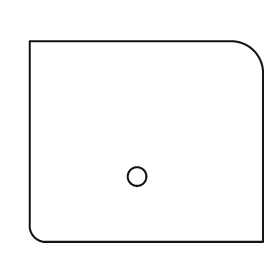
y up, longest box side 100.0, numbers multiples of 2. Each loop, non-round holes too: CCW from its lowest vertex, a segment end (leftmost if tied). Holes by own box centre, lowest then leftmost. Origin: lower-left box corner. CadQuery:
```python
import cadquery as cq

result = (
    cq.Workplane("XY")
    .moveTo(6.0, 0.0)
    .lineTo(100.0, 0.0)
    .lineTo(100.0, 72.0)
    .threePointArc((96.0, 82.0), (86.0, 86.0))
    .lineTo(0.0, 86.0)
    .lineTo(0.0, 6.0)
    .threePointArc((2.0, 2.0), (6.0, 0.0))
    .close()
    .moveTo(46.0, 28.0)
    .circle(4.0)
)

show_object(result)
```